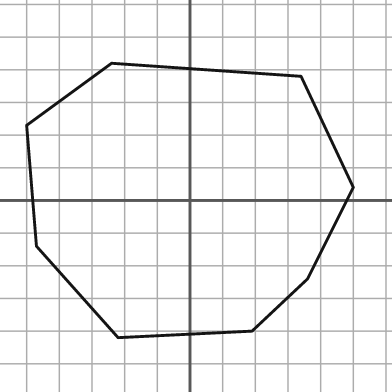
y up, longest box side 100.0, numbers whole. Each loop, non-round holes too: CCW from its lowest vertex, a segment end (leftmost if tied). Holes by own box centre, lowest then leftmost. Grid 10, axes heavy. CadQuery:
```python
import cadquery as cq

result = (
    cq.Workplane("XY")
    .moveTo(-22.0, -42.0)
    .lineTo(19.0, -40.0)
    .lineTo(36.0, -24.0)
    .lineTo(50.0, 4.0)
    .lineTo(34.0, 38.0)
    .lineTo(-24.0, 42.0)
    .lineTo(-50.0, 23.0)
    .lineTo(-47.0, -14.0)
    .close()
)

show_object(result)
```